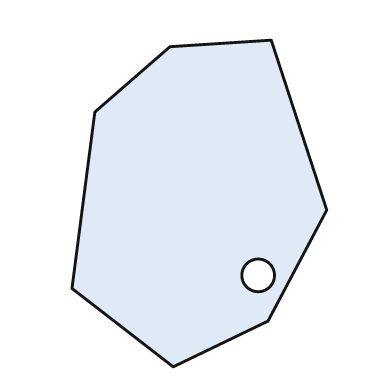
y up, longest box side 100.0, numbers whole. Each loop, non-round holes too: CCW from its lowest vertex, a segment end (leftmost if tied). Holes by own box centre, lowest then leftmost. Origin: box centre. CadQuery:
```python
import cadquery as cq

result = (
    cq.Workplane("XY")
    .moveTo(-8.0, -50.0)
    .lineTo(21.0, -36.0)
    .lineTo(39.0, -2.0)
    .lineTo(22.0, 50.0)
    .lineTo(-9.0, 48.0)
    .lineTo(-32.0, 28.0)
    .lineTo(-39.0, -26.0)
    .close()
    .moveTo(18.0, -22.0)
    .circle(5.0)
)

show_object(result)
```